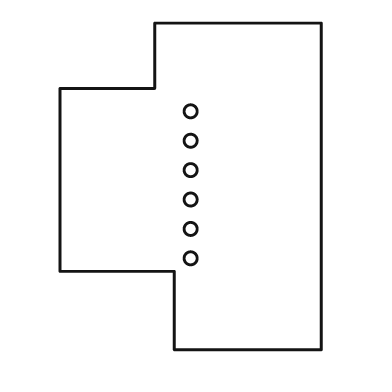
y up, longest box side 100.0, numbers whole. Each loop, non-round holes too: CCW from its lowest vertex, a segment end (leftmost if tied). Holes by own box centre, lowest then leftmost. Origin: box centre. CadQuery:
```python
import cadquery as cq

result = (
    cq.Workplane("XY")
    .moveTo(-5.0, -50.0)
    .lineTo(40.0, -50.0)
    .lineTo(40.0, 50.0)
    .lineTo(-11.0, 50.0)
    .lineTo(-11.0, 30.0)
    .lineTo(-40.0, 30.0)
    .lineTo(-40.0, -26.0)
    .lineTo(-5.0, -26.0)
    .close()
    .moveTo(0.0, -22.0)
    .circle(2.0)
    .moveTo(0.0, -13.0)
    .circle(2.0)
    .moveTo(0.0, -4.0)
    .circle(2.0)
    .moveTo(0.0, 5.0)
    .circle(2.0)
    .moveTo(0.0, 14.0)
    .circle(2.0)
    .moveTo(0.0, 23.0)
    .circle(2.0)
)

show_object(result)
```